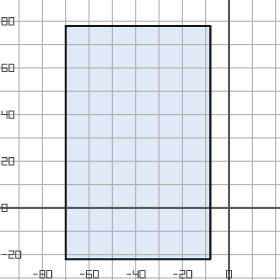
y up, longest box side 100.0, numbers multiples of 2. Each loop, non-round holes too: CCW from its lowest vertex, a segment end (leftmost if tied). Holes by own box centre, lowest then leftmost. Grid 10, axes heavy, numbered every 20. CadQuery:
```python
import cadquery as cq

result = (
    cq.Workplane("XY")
    .moveTo(-70.0, -22.0)
    .lineTo(-8.0, -22.0)
    .lineTo(-8.0, 78.0)
    .lineTo(-70.0, 78.0)
    .close()
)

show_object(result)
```